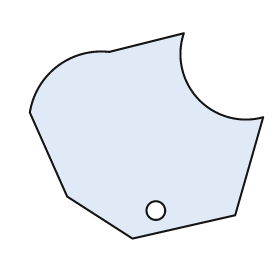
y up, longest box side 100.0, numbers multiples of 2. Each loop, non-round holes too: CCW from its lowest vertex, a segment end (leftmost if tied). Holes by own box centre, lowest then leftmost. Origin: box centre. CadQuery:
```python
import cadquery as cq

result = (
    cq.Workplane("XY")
    .moveTo(-6.0, -44.0)
    .lineTo(38.0, -34.0)
    .lineTo(50.0, 8.0)
    .threePointArc((22.0, 16.0), (16.0, 44.0))
    .lineTo(-16.0, 36.0)
    .threePointArc((-38.0, 30.0), (-50.0, 10.0))
    .lineTo(-34.0, -26.0)
    .close()
    .moveTo(4.0, -32.0)
    .circle(4.0)
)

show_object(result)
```